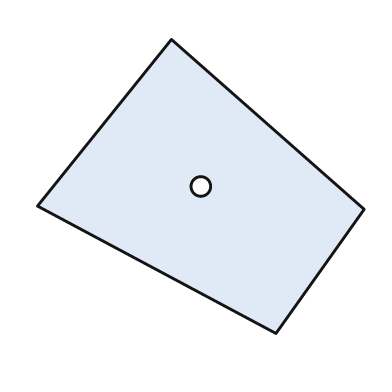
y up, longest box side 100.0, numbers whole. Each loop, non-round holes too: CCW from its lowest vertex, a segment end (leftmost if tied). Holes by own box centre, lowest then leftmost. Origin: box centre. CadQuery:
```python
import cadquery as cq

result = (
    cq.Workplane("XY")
    .moveTo(23.0, -45.0)
    .lineTo(50.0, -7.0)
    .lineTo(-9.0, 45.0)
    .lineTo(-50.0, -6.0)
    .close()
    .moveTo(0.0, 0.0)
    .circle(3.0)
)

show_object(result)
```